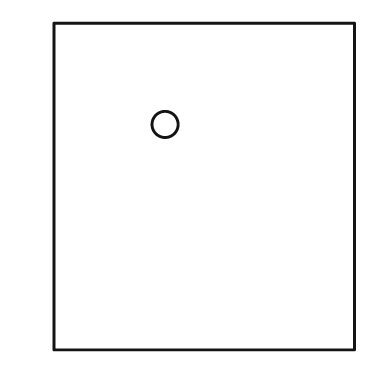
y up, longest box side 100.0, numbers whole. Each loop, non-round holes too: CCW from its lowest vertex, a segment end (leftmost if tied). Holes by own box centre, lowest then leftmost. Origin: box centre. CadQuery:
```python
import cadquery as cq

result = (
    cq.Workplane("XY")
    .moveTo(-46.0, -50.0)
    .lineTo(46.0, -50.0)
    .lineTo(46.0, 50.0)
    .lineTo(-46.0, 50.0)
    .close()
    .moveTo(-12.0, 19.0)
    .circle(4.0)
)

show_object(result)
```